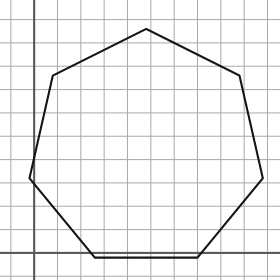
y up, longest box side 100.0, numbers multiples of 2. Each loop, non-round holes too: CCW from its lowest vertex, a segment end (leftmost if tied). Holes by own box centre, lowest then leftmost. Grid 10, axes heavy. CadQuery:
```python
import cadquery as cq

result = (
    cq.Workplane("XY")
    .moveTo(26.0, -2.0)
    .lineTo(70.0, -2.0)
    .lineTo(98.0, 32.0)
    .lineTo(88.0, 76.0)
    .lineTo(48.0, 96.0)
    .lineTo(8.0, 76.0)
    .lineTo(-2.0, 32.0)
    .close()
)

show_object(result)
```